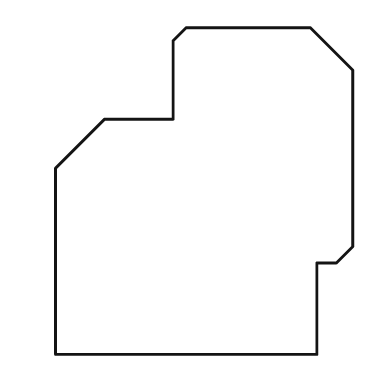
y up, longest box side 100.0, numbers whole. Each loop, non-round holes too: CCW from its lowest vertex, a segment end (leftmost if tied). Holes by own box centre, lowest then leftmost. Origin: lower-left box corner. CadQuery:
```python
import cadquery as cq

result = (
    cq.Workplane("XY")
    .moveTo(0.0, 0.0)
    .lineTo(80.0, 0.0)
    .lineTo(80.0, 28.0)
    .lineTo(86.0, 28.0)
    .lineTo(91.0, 33.0)
    .lineTo(91.0, 87.0)
    .lineTo(78.0, 100.0)
    .lineTo(40.0, 100.0)
    .lineTo(36.0, 96.0)
    .lineTo(36.0, 72.0)
    .lineTo(15.0, 72.0)
    .lineTo(0.0, 57.0)
    .close()
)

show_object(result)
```